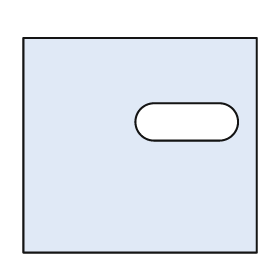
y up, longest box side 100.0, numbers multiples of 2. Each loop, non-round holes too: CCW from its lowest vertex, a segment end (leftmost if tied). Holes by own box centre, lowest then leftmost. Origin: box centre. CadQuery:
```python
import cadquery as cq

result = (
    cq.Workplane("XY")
    .moveTo(-50.0, -46.0)
    .lineTo(50.0, -46.0)
    .lineTo(50.0, 46.0)
    .lineTo(-50.0, 46.0)
    .close()
    .moveTo(6.0, 2.0)
    .lineTo(34.0, 2.0)
    .threePointArc((42.0, 10.0), (34.0, 18.0))
    .lineTo(6.0, 18.0)
    .threePointArc((-2.0, 10.0), (6.0, 2.0))
    .close()
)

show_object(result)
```